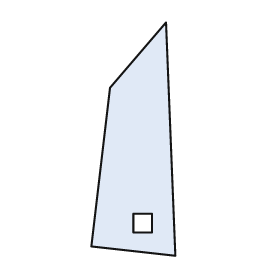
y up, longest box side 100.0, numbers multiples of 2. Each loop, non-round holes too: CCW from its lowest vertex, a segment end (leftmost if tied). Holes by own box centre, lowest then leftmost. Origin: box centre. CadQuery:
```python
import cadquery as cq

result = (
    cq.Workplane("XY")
    .moveTo(18.0, -50.0)
    .lineTo(14.0, 50.0)
    .lineTo(-10.0, 22.0)
    .lineTo(-18.0, -46.0)
    .close()
    .moveTo(0.0, -40.0)
    .lineTo(8.0, -40.0)
    .lineTo(8.0, -32.0)
    .lineTo(0.0, -32.0)
    .close()
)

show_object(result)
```